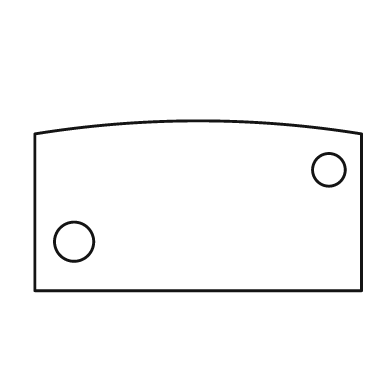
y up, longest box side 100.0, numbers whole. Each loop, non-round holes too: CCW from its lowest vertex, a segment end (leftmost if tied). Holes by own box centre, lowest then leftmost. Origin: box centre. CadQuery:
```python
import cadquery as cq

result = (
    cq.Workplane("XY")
    .moveTo(-50.0, -26.0)
    .lineTo(50.0, -26.0)
    .lineTo(50.0, 22.0)
    .threePointArc((0.0, 26.0), (-50.0, 22.0))
    .close()
    .moveTo(-38.0, -11.0)
    .circle(6.0)
    .moveTo(40.0, 11.0)
    .circle(5.0)
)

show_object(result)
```